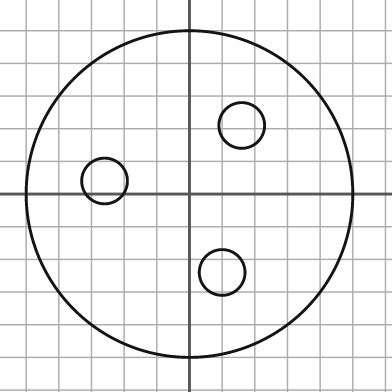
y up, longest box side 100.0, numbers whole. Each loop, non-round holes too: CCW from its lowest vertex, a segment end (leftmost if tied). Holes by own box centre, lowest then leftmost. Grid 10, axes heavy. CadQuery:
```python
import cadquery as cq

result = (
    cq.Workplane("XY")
    .moveTo(0.0, 0.0)
    .circle(50.0)
    .moveTo(10.0, -24.0)
    .circle(7.0)
    .moveTo(-26.0, 4.0)
    .circle(7.0)
    .moveTo(16.0, 21.0)
    .circle(7.0)
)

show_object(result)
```